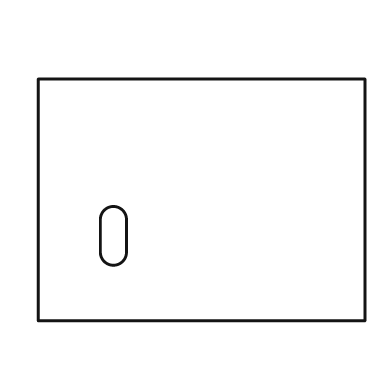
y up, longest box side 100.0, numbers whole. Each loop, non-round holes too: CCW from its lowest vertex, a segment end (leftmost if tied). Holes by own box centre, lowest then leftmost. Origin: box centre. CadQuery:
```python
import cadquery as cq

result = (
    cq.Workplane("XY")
    .moveTo(-50.0, -37.0)
    .lineTo(50.0, -37.0)
    .lineTo(50.0, 37.0)
    .lineTo(-50.0, 37.0)
    .close()
    .moveTo(-31.0, -16.0)
    .threePointArc((-27.0, -20.0), (-23.0, -16.0))
    .lineTo(-23.0, -6.0)
    .threePointArc((-27.0, -2.0), (-31.0, -6.0))
    .close()
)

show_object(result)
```